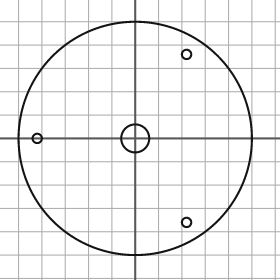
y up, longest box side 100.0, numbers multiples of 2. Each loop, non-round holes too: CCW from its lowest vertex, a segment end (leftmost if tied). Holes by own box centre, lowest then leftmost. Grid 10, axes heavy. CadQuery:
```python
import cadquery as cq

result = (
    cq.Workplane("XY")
    .moveTo(0.0, 0.0)
    .circle(50.0)
    .moveTo(22.0, -36.0)
    .circle(2.0)
    .moveTo(-42.0, 0.0)
    .circle(2.0)
    .moveTo(0.0, 0.0)
    .circle(6.0)
    .moveTo(22.0, 36.0)
    .circle(2.0)
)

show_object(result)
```